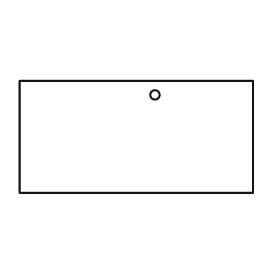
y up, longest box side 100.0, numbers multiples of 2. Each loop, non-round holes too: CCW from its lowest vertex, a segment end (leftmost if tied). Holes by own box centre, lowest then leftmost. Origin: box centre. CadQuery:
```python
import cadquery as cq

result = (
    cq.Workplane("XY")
    .moveTo(-50.0, -24.0)
    .lineTo(50.0, -24.0)
    .lineTo(50.0, 24.0)
    .lineTo(-50.0, 24.0)
    .close()
    .moveTo(8.0, 18.0)
    .circle(2.0)
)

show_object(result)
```